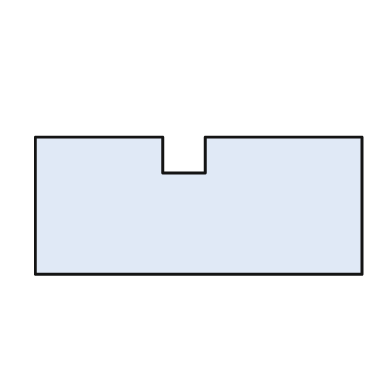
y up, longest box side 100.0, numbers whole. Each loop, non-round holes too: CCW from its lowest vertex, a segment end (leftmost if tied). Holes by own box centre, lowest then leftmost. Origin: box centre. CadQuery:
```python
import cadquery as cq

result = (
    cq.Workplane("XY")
    .moveTo(-50.0, -21.0)
    .lineTo(50.0, -21.0)
    .lineTo(50.0, 21.0)
    .lineTo(2.0, 21.0)
    .lineTo(2.0, 10.0)
    .lineTo(-11.0, 10.0)
    .lineTo(-11.0, 21.0)
    .lineTo(-50.0, 21.0)
    .close()
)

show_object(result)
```